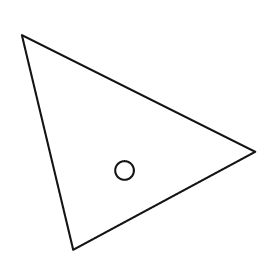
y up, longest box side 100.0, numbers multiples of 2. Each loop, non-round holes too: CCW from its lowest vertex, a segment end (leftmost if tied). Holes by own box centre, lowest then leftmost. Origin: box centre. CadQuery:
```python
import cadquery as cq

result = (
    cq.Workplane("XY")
    .moveTo(-28.0, -46.0)
    .lineTo(50.0, -4.0)
    .lineTo(-50.0, 46.0)
    .close()
    .moveTo(-6.0, -12.0)
    .circle(4.0)
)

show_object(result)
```